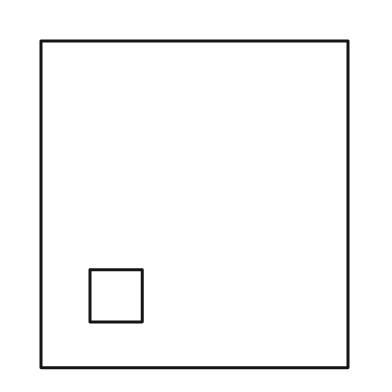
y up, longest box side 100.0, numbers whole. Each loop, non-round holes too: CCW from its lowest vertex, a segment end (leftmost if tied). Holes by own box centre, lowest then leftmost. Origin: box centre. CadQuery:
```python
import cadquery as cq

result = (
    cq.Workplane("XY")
    .moveTo(-47.0, -50.0)
    .lineTo(47.0, -50.0)
    .lineTo(47.0, 50.0)
    .lineTo(-47.0, 50.0)
    .close()
    .moveTo(-32.0, -36.0)
    .lineTo(-16.0, -36.0)
    .lineTo(-16.0, -20.0)
    .lineTo(-32.0, -20.0)
    .close()
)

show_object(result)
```